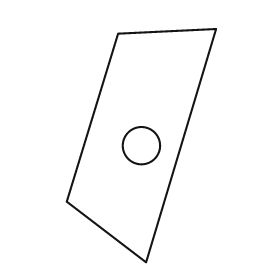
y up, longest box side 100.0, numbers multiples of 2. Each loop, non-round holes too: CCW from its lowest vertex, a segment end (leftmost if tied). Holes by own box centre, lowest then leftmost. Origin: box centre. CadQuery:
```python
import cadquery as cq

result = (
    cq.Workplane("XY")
    .moveTo(2.0, -50.0)
    .lineTo(32.0, 50.0)
    .lineTo(-10.0, 48.0)
    .lineTo(-32.0, -24.0)
    .close()
    .moveTo(0.0, 0.0)
    .circle(8.0)
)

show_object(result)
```